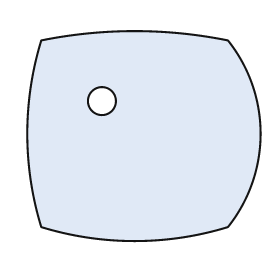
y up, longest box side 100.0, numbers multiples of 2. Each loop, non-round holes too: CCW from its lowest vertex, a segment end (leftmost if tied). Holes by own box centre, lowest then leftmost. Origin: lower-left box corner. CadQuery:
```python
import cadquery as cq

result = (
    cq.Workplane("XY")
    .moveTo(6.0, 6.0)
    .threePointArc((46.0, 0.0), (86.0, 6.0))
    .threePointArc((100.0, 46.0), (86.0, 86.0))
    .threePointArc((46.0, 90.0), (6.0, 86.0))
    .threePointArc((0.0, 46.0), (6.0, 6.0))
    .close()
    .moveTo(32.0, 60.0)
    .circle(6.0)
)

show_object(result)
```